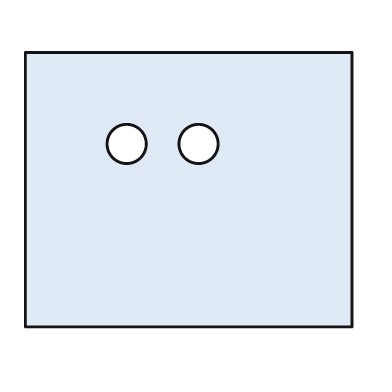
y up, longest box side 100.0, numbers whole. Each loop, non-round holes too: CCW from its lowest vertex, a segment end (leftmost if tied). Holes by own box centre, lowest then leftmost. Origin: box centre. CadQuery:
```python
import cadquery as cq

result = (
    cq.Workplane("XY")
    .moveTo(-50.0, -42.0)
    .lineTo(50.0, -42.0)
    .lineTo(50.0, 42.0)
    .lineTo(-50.0, 42.0)
    .close()
    .moveTo(-19.0, 14.0)
    .circle(6.0)
    .moveTo(3.0, 14.0)
    .circle(6.0)
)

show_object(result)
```